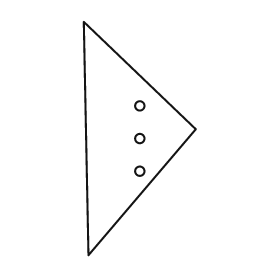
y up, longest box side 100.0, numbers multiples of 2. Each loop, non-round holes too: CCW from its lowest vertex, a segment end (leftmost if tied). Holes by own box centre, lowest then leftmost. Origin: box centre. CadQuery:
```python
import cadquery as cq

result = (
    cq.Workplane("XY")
    .moveTo(-22.0, -50.0)
    .lineTo(24.0, 4.0)
    .lineTo(-24.0, 50.0)
    .close()
    .moveTo(0.0, -14.0)
    .circle(2.0)
    .moveTo(0.0, 0.0)
    .circle(2.0)
    .moveTo(0.0, 14.0)
    .circle(2.0)
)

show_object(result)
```